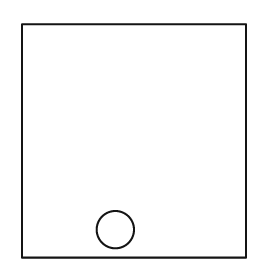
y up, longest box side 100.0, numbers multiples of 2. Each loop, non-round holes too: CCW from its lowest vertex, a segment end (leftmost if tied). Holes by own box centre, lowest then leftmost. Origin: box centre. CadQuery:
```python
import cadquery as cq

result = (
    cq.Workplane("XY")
    .moveTo(-48.0, -50.0)
    .lineTo(48.0, -50.0)
    .lineTo(48.0, 50.0)
    .lineTo(-48.0, 50.0)
    .close()
    .moveTo(-8.0, -38.0)
    .circle(8.0)
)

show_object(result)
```